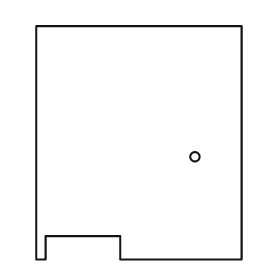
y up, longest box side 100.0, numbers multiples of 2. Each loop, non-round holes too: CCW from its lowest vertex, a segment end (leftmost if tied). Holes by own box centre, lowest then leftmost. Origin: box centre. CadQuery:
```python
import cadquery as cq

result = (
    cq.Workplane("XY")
    .moveTo(-44.0, -50.0)
    .lineTo(-40.0, -50.0)
    .lineTo(-40.0, -40.0)
    .lineTo(-8.0, -40.0)
    .lineTo(-8.0, -50.0)
    .lineTo(44.0, -50.0)
    .lineTo(44.0, 50.0)
    .lineTo(-44.0, 50.0)
    .close()
    .moveTo(24.0, -6.0)
    .circle(2.0)
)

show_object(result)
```